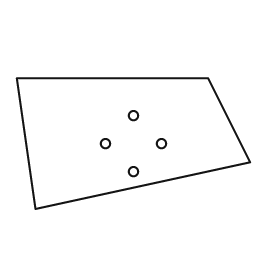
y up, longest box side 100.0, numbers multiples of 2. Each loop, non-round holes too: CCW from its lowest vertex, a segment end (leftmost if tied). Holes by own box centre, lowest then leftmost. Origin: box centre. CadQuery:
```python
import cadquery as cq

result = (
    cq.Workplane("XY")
    .moveTo(-42.0, -28.0)
    .lineTo(50.0, -8.0)
    .lineTo(32.0, 28.0)
    .lineTo(-50.0, 28.0)
    .close()
    .moveTo(0.0, -12.0)
    .circle(2.0)
    .moveTo(-12.0, 0.0)
    .circle(2.0)
    .moveTo(12.0, 0.0)
    .circle(2.0)
    .moveTo(0.0, 12.0)
    .circle(2.0)
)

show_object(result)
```